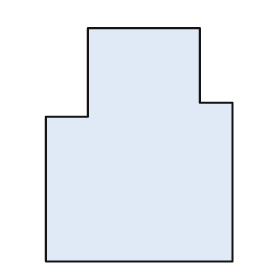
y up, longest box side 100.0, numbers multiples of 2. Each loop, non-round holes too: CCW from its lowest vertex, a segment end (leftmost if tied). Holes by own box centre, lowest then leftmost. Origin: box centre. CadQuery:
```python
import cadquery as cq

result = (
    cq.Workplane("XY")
    .moveTo(-40.0, -50.0)
    .lineTo(40.0, -50.0)
    .lineTo(40.0, 18.0)
    .lineTo(26.0, 18.0)
    .lineTo(26.0, 50.0)
    .lineTo(-22.0, 50.0)
    .lineTo(-22.0, 12.0)
    .lineTo(-40.0, 12.0)
    .close()
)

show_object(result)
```